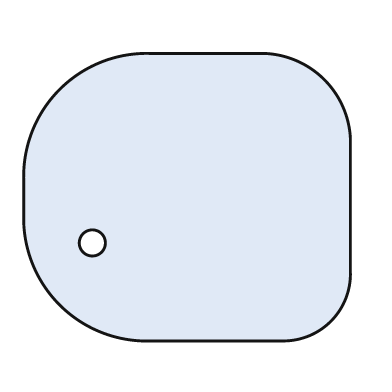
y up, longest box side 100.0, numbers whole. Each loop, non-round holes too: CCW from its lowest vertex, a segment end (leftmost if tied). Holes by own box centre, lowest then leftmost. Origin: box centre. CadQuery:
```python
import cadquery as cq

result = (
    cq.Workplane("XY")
    .moveTo(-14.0, -44.0)
    .lineTo(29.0, -44.0)
    .threePointArc((44.0, -38.0), (50.0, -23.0))
    .lineTo(50.0, 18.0)
    .threePointArc((42.0, 36.0), (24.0, 44.0))
    .lineTo(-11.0, 44.0)
    .threePointArc((-39.0, 33.0), (-50.0, 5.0))
    .lineTo(-50.0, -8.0)
    .threePointArc((-39.0, -33.0), (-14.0, -44.0))
    .close()
    .moveTo(-29.0, -14.0)
    .circle(4.0)
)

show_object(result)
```